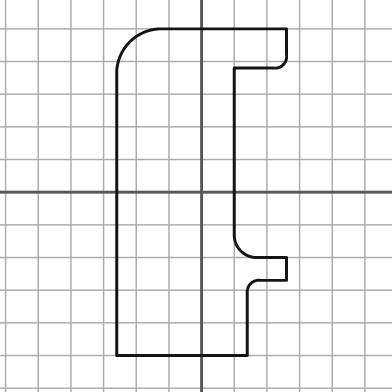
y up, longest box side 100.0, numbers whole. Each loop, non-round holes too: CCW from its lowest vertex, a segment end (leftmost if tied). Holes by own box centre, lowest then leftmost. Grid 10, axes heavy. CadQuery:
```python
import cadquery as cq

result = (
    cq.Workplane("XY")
    .moveTo(-26.0, -50.0)
    .lineTo(14.0, -50.0)
    .lineTo(14.0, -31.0)
    .threePointArc((15.0, -28.0), (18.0, -27.0))
    .lineTo(26.0, -27.0)
    .lineTo(26.0, -20.0)
    .lineTo(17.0, -20.0)
    .threePointArc((12.0, -18.0), (10.0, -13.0))
    .lineTo(10.0, 38.0)
    .lineTo(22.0, 38.0)
    .threePointArc((25.0, 39.0), (26.0, 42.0))
    .lineTo(26.0, 50.0)
    .lineTo(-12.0, 50.0)
    .threePointArc((-22.0, 46.0), (-26.0, 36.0))
    .close()
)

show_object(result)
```